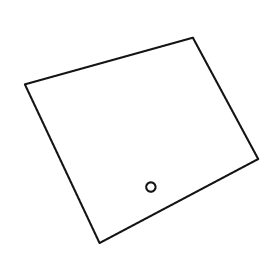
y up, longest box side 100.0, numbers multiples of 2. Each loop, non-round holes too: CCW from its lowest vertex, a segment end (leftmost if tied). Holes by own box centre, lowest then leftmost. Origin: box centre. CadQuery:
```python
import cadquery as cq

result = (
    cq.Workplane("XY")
    .moveTo(-18.0, -44.0)
    .lineTo(50.0, -8.0)
    .lineTo(22.0, 44.0)
    .lineTo(-50.0, 24.0)
    .close()
    .moveTo(4.0, -20.0)
    .circle(2.0)
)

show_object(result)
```